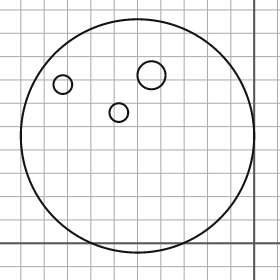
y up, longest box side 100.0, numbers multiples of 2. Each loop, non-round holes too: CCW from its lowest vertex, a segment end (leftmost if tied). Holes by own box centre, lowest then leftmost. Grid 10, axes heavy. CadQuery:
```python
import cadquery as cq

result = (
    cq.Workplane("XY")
    .moveTo(-50.0, 46.0)
    .circle(50.0)
    .moveTo(-58.0, 56.0)
    .circle(4.0)
    .moveTo(-82.0, 68.0)
    .circle(4.0)
    .moveTo(-44.0, 72.0)
    .circle(6.0)
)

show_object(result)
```